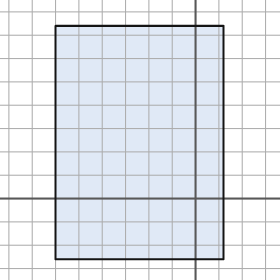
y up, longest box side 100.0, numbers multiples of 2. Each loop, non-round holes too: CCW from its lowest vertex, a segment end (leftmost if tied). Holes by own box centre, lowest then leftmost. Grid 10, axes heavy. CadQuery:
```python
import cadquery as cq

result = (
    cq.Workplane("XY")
    .moveTo(-60.0, -26.0)
    .lineTo(12.0, -26.0)
    .lineTo(12.0, 74.0)
    .lineTo(-60.0, 74.0)
    .close()
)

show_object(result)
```